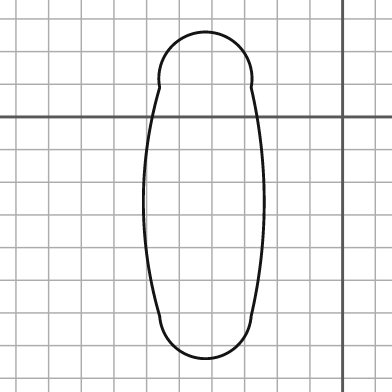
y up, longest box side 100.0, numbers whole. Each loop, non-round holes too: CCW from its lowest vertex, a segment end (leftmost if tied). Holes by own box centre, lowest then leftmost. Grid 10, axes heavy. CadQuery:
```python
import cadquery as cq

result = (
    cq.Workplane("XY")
    .moveTo(-56.0, -61.0)
    .threePointArc((-42.0, -74.0), (-28.0, -61.0))
    .threePointArc((-24.0, -26.0), (-28.0, 9.0))
    .threePointArc((-42.0, 26.0), (-56.0, 9.0))
    .threePointArc((-61.0, -26.0), (-56.0, -61.0))
    .close()
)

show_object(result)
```